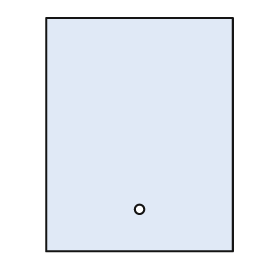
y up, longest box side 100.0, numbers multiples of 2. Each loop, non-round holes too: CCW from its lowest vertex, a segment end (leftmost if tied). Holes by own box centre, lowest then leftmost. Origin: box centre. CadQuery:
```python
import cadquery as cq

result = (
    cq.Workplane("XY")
    .moveTo(-40.0, -50.0)
    .lineTo(40.0, -50.0)
    .lineTo(40.0, 50.0)
    .lineTo(-40.0, 50.0)
    .close()
    .moveTo(0.0, -32.0)
    .circle(2.0)
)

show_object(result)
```